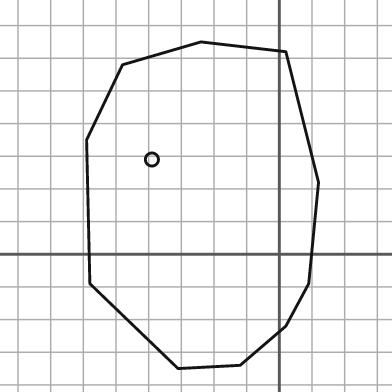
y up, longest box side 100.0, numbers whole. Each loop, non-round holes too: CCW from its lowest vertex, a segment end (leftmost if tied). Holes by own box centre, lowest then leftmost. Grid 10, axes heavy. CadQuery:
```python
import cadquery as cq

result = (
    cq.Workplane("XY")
    .moveTo(-31.0, -35.0)
    .lineTo(-12.0, -34.0)
    .lineTo(2.0, -22.0)
    .lineTo(9.0, -9.0)
    .lineTo(12.0, 22.0)
    .lineTo(2.0, 62.0)
    .lineTo(-24.0, 65.0)
    .lineTo(-48.0, 58.0)
    .lineTo(-59.0, 35.0)
    .lineTo(-58.0, -9.0)
    .close()
    .moveTo(-39.0, 29.0)
    .circle(2.0)
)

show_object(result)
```